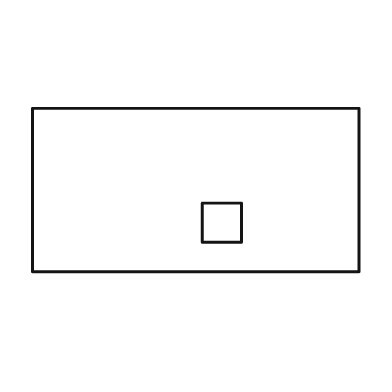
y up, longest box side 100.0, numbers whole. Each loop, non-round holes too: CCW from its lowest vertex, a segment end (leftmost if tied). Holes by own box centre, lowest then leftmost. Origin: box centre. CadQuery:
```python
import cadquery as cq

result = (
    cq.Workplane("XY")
    .moveTo(-50.0, -25.0)
    .lineTo(50.0, -25.0)
    .lineTo(50.0, 25.0)
    .lineTo(-50.0, 25.0)
    .close()
    .moveTo(2.0, -16.0)
    .lineTo(14.0, -16.0)
    .lineTo(14.0, -4.0)
    .lineTo(2.0, -4.0)
    .close()
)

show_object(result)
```